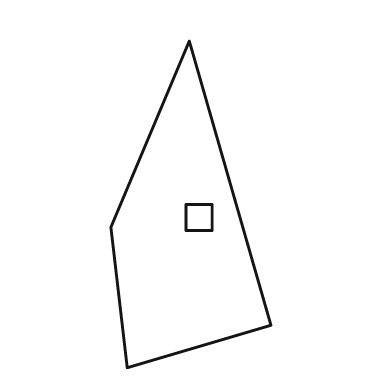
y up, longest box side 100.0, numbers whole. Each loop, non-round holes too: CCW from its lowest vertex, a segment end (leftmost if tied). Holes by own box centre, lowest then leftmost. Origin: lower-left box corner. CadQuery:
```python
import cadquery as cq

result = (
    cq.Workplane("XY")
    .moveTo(5.0, 0.0)
    .lineTo(49.0, 13.0)
    .lineTo(24.0, 100.0)
    .lineTo(0.0, 43.0)
    .close()
    .moveTo(23.0, 42.0)
    .lineTo(31.0, 42.0)
    .lineTo(31.0, 50.0)
    .lineTo(23.0, 50.0)
    .close()
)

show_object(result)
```